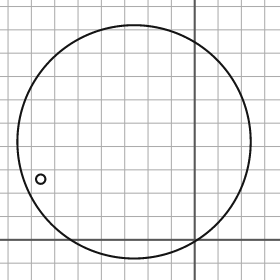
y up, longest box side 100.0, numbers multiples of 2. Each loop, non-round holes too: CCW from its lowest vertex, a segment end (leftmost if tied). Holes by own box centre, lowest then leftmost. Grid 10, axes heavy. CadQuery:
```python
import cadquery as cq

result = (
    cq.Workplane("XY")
    .moveTo(-26.0, 42.0)
    .circle(50.0)
    .moveTo(-66.0, 26.0)
    .circle(2.0)
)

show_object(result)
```